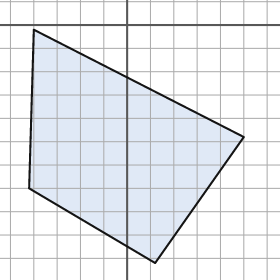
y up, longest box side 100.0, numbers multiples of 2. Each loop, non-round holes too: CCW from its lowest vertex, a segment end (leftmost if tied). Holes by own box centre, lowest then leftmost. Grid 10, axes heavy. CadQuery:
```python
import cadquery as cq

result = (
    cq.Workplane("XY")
    .moveTo(12.0, -102.0)
    .lineTo(50.0, -48.0)
    .lineTo(-40.0, -2.0)
    .lineTo(-42.0, -70.0)
    .close()
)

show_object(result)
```